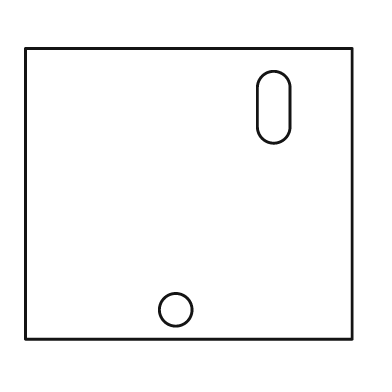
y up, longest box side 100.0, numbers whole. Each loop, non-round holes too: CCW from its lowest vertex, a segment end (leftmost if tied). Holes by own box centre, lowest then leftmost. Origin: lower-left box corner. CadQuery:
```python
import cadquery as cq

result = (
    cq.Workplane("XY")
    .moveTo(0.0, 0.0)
    .lineTo(100.0, 0.0)
    .lineTo(100.0, 89.0)
    .lineTo(0.0, 89.0)
    .close()
    .moveTo(46.0, 9.0)
    .circle(5.0)
    .moveTo(71.0, 65.0)
    .threePointArc((76.0, 60.0), (81.0, 65.0))
    .lineTo(81.0, 77.0)
    .threePointArc((76.0, 82.0), (71.0, 77.0))
    .close()
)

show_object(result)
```